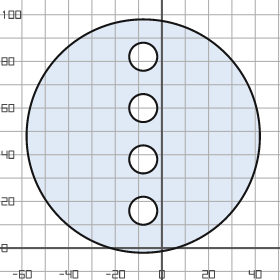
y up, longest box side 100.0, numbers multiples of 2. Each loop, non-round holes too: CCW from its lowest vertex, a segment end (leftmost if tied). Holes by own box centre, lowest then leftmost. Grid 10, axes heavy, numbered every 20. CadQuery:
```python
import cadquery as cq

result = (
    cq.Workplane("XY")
    .moveTo(-8.0, 48.0)
    .circle(50.0)
    .moveTo(-8.0, 16.0)
    .circle(6.0)
    .moveTo(-8.0, 38.0)
    .circle(6.0)
    .moveTo(-8.0, 60.0)
    .circle(6.0)
    .moveTo(-8.0, 82.0)
    .circle(6.0)
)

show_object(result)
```